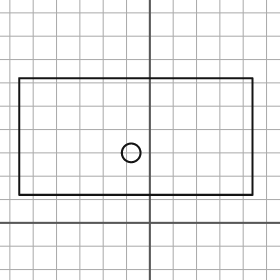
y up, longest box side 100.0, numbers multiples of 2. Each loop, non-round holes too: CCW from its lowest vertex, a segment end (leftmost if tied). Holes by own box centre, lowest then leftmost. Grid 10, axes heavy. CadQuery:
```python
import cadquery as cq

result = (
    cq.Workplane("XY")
    .moveTo(-56.0, 12.0)
    .lineTo(44.0, 12.0)
    .lineTo(44.0, 62.0)
    .lineTo(-56.0, 62.0)
    .close()
    .moveTo(-8.0, 30.0)
    .circle(4.0)
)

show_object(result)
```